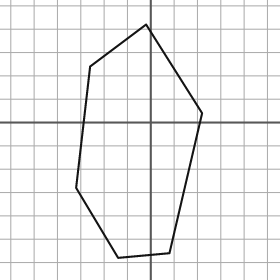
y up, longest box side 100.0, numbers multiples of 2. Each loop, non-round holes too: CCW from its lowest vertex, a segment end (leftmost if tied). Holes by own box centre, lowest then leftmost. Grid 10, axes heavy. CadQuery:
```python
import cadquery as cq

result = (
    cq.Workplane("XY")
    .moveTo(-14.0, -58.0)
    .lineTo(8.0, -56.0)
    .lineTo(22.0, 4.0)
    .lineTo(-2.0, 42.0)
    .lineTo(-26.0, 24.0)
    .lineTo(-32.0, -28.0)
    .close()
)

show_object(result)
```